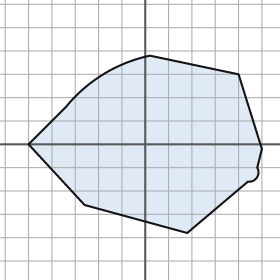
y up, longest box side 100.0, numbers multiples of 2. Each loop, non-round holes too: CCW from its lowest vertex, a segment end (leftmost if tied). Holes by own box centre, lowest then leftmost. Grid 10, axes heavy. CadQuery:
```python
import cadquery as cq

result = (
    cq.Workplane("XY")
    .moveTo(18.0, -38.0)
    .lineTo(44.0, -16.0)
    .threePointArc((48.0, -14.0), (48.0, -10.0))
    .lineTo(50.0, -2.0)
    .lineTo(40.0, 30.0)
    .lineTo(2.0, 38.0)
    .threePointArc((-18.0, 30.0), (-34.0, 16.0))
    .lineTo(-50.0, 0.0)
    .lineTo(-26.0, -26.0)
    .close()
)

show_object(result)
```